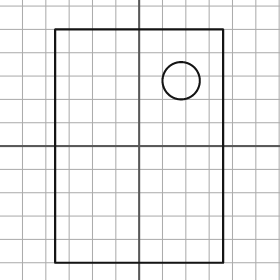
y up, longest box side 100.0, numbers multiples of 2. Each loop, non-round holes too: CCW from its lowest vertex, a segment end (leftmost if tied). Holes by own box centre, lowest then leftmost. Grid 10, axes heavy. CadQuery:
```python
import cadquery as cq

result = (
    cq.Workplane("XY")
    .moveTo(-36.0, -50.0)
    .lineTo(36.0, -50.0)
    .lineTo(36.0, 50.0)
    .lineTo(-36.0, 50.0)
    .close()
    .moveTo(18.0, 28.0)
    .circle(8.0)
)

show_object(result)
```